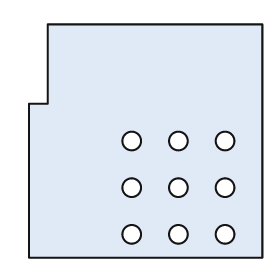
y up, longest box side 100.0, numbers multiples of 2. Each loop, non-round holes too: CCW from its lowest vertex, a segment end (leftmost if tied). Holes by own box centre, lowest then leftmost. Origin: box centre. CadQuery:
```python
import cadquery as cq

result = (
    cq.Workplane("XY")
    .moveTo(-50.0, -50.0)
    .lineTo(50.0, -50.0)
    .lineTo(50.0, 50.0)
    .lineTo(-42.0, 50.0)
    .lineTo(-42.0, 16.0)
    .lineTo(-50.0, 16.0)
    .close()
    .moveTo(-6.0, -40.0)
    .circle(4.0)
    .moveTo(14.0, -40.0)
    .circle(4.0)
    .moveTo(34.0, -40.0)
    .circle(4.0)
    .moveTo(-6.0, -20.0)
    .circle(4.0)
    .moveTo(14.0, -20.0)
    .circle(4.0)
    .moveTo(34.0, -20.0)
    .circle(4.0)
    .moveTo(-6.0, 0.0)
    .circle(4.0)
    .moveTo(14.0, 0.0)
    .circle(4.0)
    .moveTo(34.0, 0.0)
    .circle(4.0)
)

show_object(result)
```